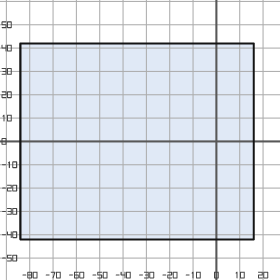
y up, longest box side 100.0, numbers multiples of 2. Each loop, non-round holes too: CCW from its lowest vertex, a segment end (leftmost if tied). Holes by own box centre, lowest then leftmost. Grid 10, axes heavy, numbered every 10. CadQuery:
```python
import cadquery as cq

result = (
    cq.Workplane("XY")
    .moveTo(-84.0, -42.0)
    .lineTo(16.0, -42.0)
    .lineTo(16.0, 42.0)
    .lineTo(-84.0, 42.0)
    .close()
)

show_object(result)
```